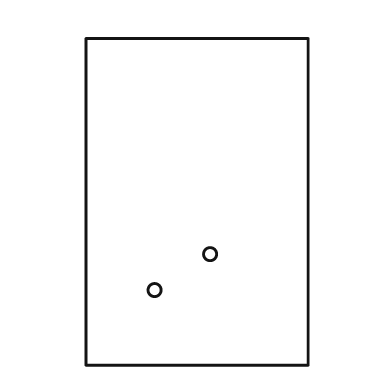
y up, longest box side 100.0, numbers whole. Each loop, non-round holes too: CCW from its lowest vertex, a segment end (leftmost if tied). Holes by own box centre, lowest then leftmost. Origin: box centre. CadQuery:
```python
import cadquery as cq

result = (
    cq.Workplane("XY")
    .moveTo(-34.0, -50.0)
    .lineTo(34.0, -50.0)
    .lineTo(34.0, 50.0)
    .lineTo(-34.0, 50.0)
    .close()
    .moveTo(-13.0, -27.0)
    .circle(2.0)
    .moveTo(4.0, -16.0)
    .circle(2.0)
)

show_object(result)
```